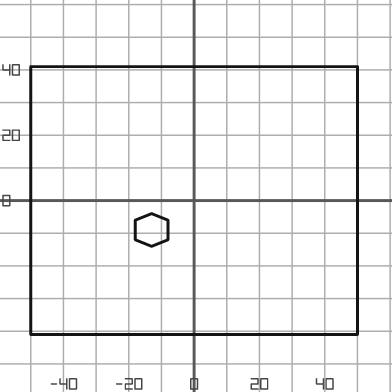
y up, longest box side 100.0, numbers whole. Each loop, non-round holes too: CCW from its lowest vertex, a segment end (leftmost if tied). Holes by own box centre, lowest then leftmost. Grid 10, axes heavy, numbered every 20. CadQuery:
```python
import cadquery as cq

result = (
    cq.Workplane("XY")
    .moveTo(-50.0, -41.0)
    .lineTo(50.0, -41.0)
    .lineTo(50.0, 41.0)
    .lineTo(-50.0, 41.0)
    .close()
    .moveTo(-13.0, -14.0)
    .lineTo(-8.0, -12.0)
    .lineTo(-8.0, -6.0)
    .lineTo(-13.0, -4.0)
    .lineTo(-18.0, -6.0)
    .lineTo(-18.0, -12.0)
    .close()
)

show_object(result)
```